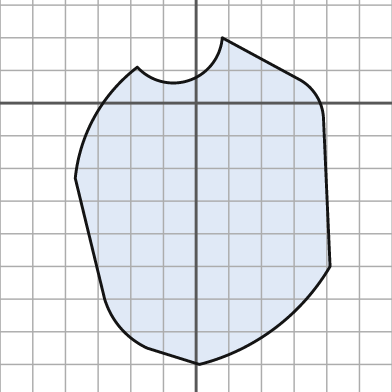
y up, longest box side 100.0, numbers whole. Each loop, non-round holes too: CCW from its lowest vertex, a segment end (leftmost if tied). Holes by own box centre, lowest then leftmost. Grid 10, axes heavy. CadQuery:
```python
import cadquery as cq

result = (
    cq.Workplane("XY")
    .moveTo(1.0, -80.0)
    .threePointArc((24.0, -69.0), (41.0, -50.0))
    .lineTo(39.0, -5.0)
    .threePointArc((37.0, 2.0), (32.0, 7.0))
    .lineTo(8.0, 20.0)
    .threePointArc((-2.0, 7.0), (-18.0, 11.0))
    .threePointArc((-31.0, -4.0), (-37.0, -23.0))
    .lineTo(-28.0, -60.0)
    .threePointArc((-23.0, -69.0), (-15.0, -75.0))
    .close()
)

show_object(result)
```